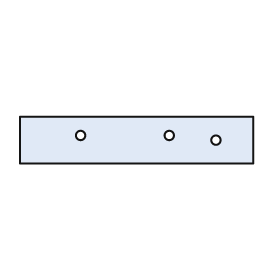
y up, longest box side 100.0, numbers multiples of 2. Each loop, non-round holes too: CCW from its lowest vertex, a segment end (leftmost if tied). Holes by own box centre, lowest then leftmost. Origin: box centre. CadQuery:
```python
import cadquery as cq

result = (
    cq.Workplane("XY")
    .moveTo(-50.0, -10.0)
    .lineTo(50.0, -10.0)
    .lineTo(50.0, 10.0)
    .lineTo(-50.0, 10.0)
    .close()
    .moveTo(34.0, 0.0)
    .circle(2.0)
    .moveTo(-24.0, 2.0)
    .circle(2.0)
    .moveTo(14.0, 2.0)
    .circle(2.0)
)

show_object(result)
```